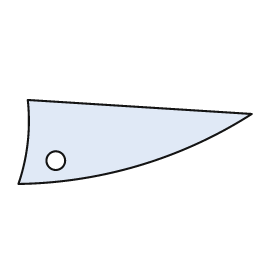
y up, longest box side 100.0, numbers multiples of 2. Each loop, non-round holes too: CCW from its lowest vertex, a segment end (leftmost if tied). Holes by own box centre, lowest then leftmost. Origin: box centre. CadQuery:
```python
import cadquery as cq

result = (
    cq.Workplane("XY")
    .moveTo(-50.0, -18.0)
    .threePointArc((2.0, -10.0), (50.0, 12.0))
    .lineTo(-46.0, 18.0)
    .threePointArc((-46.0, 0.0), (-50.0, -18.0))
    .close()
    .moveTo(-34.0, -8.0)
    .circle(4.0)
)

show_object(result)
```